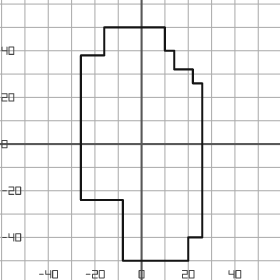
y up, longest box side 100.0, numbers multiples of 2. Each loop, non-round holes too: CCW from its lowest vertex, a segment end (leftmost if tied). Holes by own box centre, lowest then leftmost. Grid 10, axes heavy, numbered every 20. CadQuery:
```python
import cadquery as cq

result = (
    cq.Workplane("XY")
    .moveTo(-8.0, -50.0)
    .lineTo(20.0, -50.0)
    .lineTo(20.0, -40.0)
    .lineTo(26.0, -40.0)
    .lineTo(26.0, 26.0)
    .lineTo(22.0, 26.0)
    .lineTo(22.0, 32.0)
    .lineTo(14.0, 32.0)
    .lineTo(14.0, 40.0)
    .lineTo(10.0, 40.0)
    .lineTo(10.0, 50.0)
    .lineTo(-16.0, 50.0)
    .lineTo(-16.0, 38.0)
    .lineTo(-26.0, 38.0)
    .lineTo(-26.0, -24.0)
    .lineTo(-8.0, -24.0)
    .close()
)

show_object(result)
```